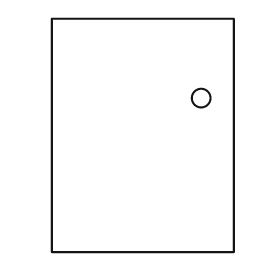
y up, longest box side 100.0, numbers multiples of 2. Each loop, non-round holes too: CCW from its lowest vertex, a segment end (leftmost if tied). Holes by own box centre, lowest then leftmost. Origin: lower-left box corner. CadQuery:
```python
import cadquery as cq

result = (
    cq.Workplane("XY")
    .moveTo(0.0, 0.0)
    .lineTo(78.0, 0.0)
    .lineTo(78.0, 100.0)
    .lineTo(0.0, 100.0)
    .close()
    .moveTo(64.0, 66.0)
    .circle(4.0)
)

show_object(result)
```